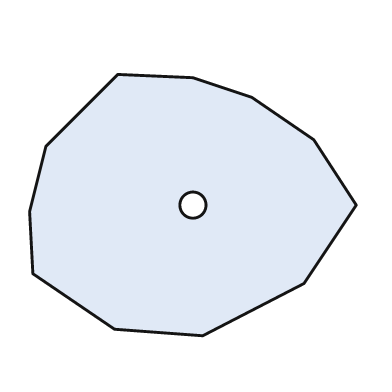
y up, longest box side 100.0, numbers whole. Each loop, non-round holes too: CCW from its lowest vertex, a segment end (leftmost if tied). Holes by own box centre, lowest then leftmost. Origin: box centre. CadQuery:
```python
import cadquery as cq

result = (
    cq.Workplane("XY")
    .moveTo(3.0, -40.0)
    .lineTo(34.0, -24.0)
    .lineTo(50.0, 0.0)
    .lineTo(37.0, 20.0)
    .lineTo(18.0, 33.0)
    .lineTo(0.0, 39.0)
    .lineTo(-23.0, 40.0)
    .lineTo(-45.0, 18.0)
    .lineTo(-50.0, -2.0)
    .lineTo(-49.0, -21.0)
    .lineTo(-24.0, -38.0)
    .close()
    .moveTo(0.0, 0.0)
    .circle(4.0)
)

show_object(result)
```